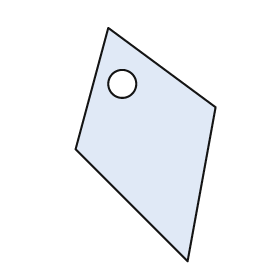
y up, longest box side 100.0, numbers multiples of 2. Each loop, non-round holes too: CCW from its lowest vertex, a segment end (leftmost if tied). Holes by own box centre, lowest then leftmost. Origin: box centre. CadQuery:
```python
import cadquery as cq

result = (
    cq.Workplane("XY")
    .moveTo(18.0, -50.0)
    .lineTo(30.0, 16.0)
    .lineTo(-16.0, 50.0)
    .lineTo(-30.0, -2.0)
    .close()
    .moveTo(-10.0, 26.0)
    .circle(6.0)
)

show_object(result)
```